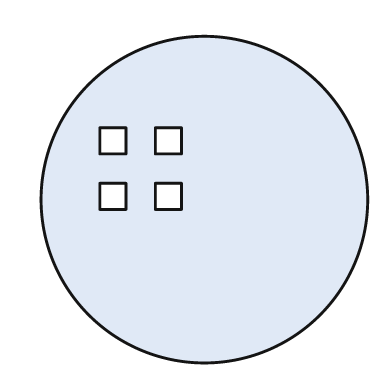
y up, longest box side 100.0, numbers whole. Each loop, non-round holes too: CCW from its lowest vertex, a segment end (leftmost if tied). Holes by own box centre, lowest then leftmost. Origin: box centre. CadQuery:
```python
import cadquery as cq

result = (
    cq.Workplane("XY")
    .moveTo(0.0, 0.0)
    .circle(50.0)
    .moveTo(-32.0, -3.0)
    .lineTo(-24.0, -3.0)
    .lineTo(-24.0, 5.0)
    .lineTo(-32.0, 5.0)
    .close()
    .moveTo(-15.0, -3.0)
    .lineTo(-7.0, -3.0)
    .lineTo(-7.0, 5.0)
    .lineTo(-15.0, 5.0)
    .close()
    .moveTo(-32.0, 14.0)
    .lineTo(-24.0, 14.0)
    .lineTo(-24.0, 22.0)
    .lineTo(-32.0, 22.0)
    .close()
    .moveTo(-15.0, 14.0)
    .lineTo(-7.0, 14.0)
    .lineTo(-7.0, 22.0)
    .lineTo(-15.0, 22.0)
    .close()
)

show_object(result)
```